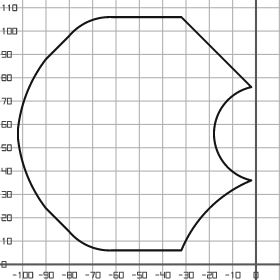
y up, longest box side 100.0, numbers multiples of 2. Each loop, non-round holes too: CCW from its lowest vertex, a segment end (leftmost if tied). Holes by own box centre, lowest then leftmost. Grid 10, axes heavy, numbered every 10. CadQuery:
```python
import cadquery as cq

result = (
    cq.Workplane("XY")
    .moveTo(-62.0, 6.0)
    .lineTo(-32.0, 6.0)
    .threePointArc((-20.0, 24.0), (-2.0, 36.0))
    .threePointArc((-18.0, 56.0), (-2.0, 76.0))
    .lineTo(-32.0, 106.0)
    .lineTo(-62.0, 106.0)
    .threePointArc((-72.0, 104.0), (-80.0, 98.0))
    .lineTo(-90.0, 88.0)
    .threePointArc((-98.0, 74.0), (-102.0, 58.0))
    .lineTo(-102.0, 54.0)
    .threePointArc((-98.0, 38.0), (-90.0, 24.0))
    .lineTo(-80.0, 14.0)
    .threePointArc((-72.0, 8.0), (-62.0, 6.0))
    .close()
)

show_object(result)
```